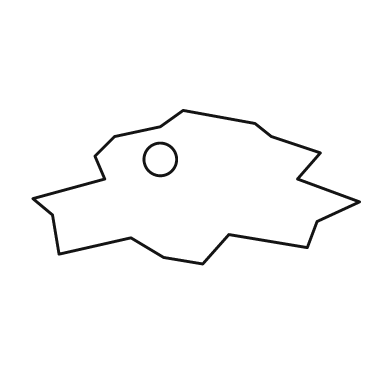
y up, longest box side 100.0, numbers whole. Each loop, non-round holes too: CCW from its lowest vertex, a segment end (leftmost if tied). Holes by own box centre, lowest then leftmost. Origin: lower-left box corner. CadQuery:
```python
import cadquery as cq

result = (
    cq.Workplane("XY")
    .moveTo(52.0, 0.0)
    .lineTo(60.0, 9.0)
    .lineTo(84.0, 5.0)
    .lineTo(87.0, 13.0)
    .lineTo(100.0, 19.0)
    .lineTo(81.0, 26.0)
    .lineTo(88.0, 34.0)
    .lineTo(73.0, 39.0)
    .lineTo(68.0, 43.0)
    .lineTo(46.0, 47.0)
    .lineTo(39.0, 42.0)
    .lineTo(25.0, 39.0)
    .lineTo(19.0, 33.0)
    .lineTo(22.0, 26.0)
    .lineTo(0.0, 20.0)
    .lineTo(6.0, 15.0)
    .lineTo(8.0, 3.0)
    .lineTo(30.0, 8.0)
    .lineTo(40.0, 2.0)
    .close()
    .moveTo(39.0, 32.0)
    .circle(5.0)
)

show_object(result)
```